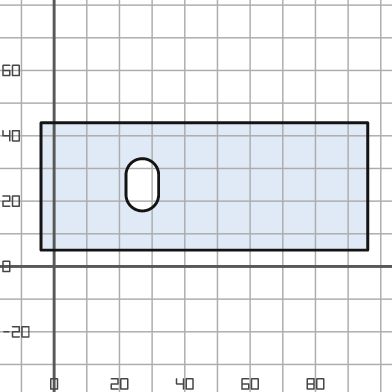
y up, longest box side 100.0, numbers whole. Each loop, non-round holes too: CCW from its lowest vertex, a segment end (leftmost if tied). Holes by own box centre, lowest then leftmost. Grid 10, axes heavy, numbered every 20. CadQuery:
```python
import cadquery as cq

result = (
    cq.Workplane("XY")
    .moveTo(-4.0, 5.0)
    .lineTo(96.0, 5.0)
    .lineTo(96.0, 44.0)
    .lineTo(-4.0, 44.0)
    .close()
    .moveTo(22.0, 22.0)
    .threePointArc((27.0, 17.0), (32.0, 22.0))
    .lineTo(32.0, 28.0)
    .threePointArc((27.0, 33.0), (22.0, 28.0))
    .close()
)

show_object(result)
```